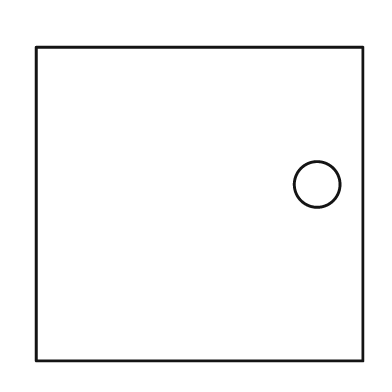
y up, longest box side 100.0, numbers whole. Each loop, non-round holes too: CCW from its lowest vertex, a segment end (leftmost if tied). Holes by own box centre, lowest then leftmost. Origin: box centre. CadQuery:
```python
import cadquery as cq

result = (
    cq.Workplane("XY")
    .moveTo(-50.0, -48.0)
    .lineTo(50.0, -48.0)
    .lineTo(50.0, 48.0)
    .lineTo(-50.0, 48.0)
    .close()
    .moveTo(36.0, 6.0)
    .circle(7.0)
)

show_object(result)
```